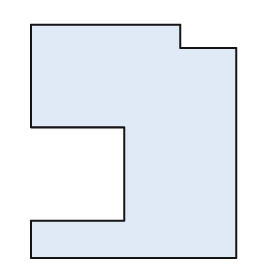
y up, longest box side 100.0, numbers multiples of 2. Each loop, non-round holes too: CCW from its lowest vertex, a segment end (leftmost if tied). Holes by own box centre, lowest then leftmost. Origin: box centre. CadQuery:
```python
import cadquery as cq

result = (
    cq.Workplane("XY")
    .moveTo(-44.0, -50.0)
    .lineTo(44.0, -50.0)
    .lineTo(44.0, 40.0)
    .lineTo(20.0, 40.0)
    .lineTo(20.0, 50.0)
    .lineTo(-44.0, 50.0)
    .lineTo(-44.0, 6.0)
    .lineTo(-4.0, 6.0)
    .lineTo(-4.0, -34.0)
    .lineTo(-44.0, -34.0)
    .close()
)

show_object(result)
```